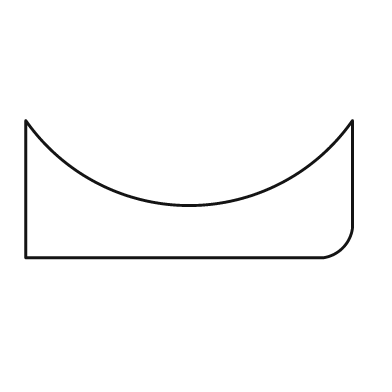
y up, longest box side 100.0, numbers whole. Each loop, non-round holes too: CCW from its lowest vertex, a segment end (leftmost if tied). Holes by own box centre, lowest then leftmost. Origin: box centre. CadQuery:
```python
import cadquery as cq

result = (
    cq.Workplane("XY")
    .moveTo(-50.0, -21.0)
    .lineTo(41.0, -21.0)
    .threePointArc((47.0, -18.0), (50.0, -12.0))
    .lineTo(50.0, 21.0)
    .threePointArc((0.0, -5.0), (-50.0, 21.0))
    .close()
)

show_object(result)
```